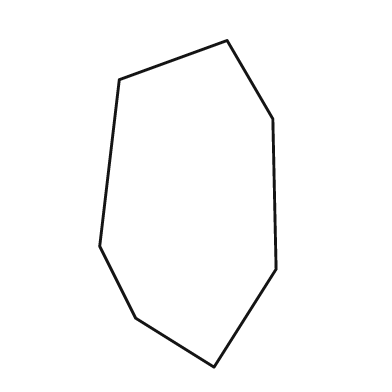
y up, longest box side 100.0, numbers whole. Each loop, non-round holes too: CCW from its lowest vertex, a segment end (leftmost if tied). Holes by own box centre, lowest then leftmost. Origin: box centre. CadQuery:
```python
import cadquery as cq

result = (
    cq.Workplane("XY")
    .moveTo(8.0, -50.0)
    .lineTo(27.0, -20.0)
    .lineTo(26.0, 26.0)
    .lineTo(12.0, 50.0)
    .lineTo(-21.0, 38.0)
    .lineTo(-27.0, -13.0)
    .lineTo(-16.0, -35.0)
    .close()
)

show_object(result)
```